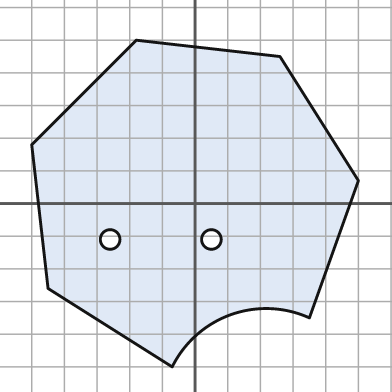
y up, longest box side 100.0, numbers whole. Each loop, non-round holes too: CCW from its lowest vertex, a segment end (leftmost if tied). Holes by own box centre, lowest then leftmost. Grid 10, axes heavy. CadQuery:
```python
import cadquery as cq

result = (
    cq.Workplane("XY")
    .moveTo(-7.0, -50.0)
    .threePointArc((11.0, -34.0), (35.0, -35.0))
    .lineTo(50.0, 7.0)
    .lineTo(26.0, 45.0)
    .lineTo(-18.0, 50.0)
    .lineTo(-50.0, 18.0)
    .lineTo(-45.0, -26.0)
    .close()
    .moveTo(-26.0, -11.0)
    .circle(3.0)
    .moveTo(5.0, -11.0)
    .circle(3.0)
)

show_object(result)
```